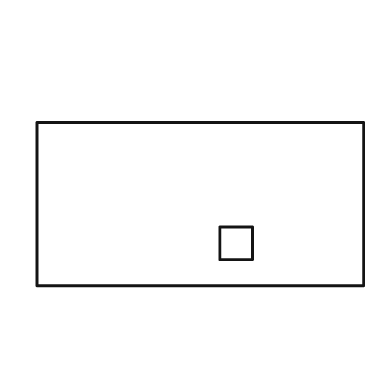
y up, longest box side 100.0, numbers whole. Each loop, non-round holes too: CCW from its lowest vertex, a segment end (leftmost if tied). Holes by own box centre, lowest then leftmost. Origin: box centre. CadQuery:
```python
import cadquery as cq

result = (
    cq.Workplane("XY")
    .moveTo(-50.0, -25.0)
    .lineTo(50.0, -25.0)
    .lineTo(50.0, 25.0)
    .lineTo(-50.0, 25.0)
    .close()
    .moveTo(6.0, -17.0)
    .lineTo(16.0, -17.0)
    .lineTo(16.0, -7.0)
    .lineTo(6.0, -7.0)
    .close()
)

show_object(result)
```